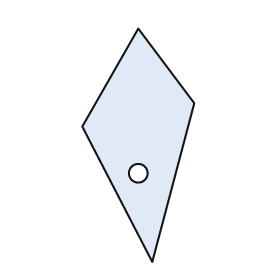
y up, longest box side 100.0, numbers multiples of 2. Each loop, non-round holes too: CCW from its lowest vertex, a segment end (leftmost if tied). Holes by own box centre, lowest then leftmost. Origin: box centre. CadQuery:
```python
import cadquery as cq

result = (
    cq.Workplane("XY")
    .moveTo(6.0, -50.0)
    .lineTo(24.0, 18.0)
    .lineTo(0.0, 50.0)
    .lineTo(-24.0, 8.0)
    .close()
    .moveTo(0.0, -12.0)
    .circle(4.0)
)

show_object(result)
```